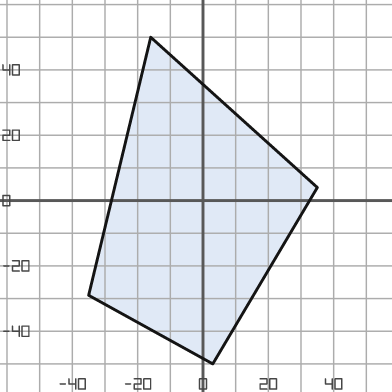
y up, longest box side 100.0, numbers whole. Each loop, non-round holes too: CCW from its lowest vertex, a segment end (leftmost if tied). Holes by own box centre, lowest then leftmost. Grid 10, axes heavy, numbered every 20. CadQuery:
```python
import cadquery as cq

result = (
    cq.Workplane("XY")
    .moveTo(3.0, -50.0)
    .lineTo(35.0, 4.0)
    .lineTo(-16.0, 50.0)
    .lineTo(-35.0, -29.0)
    .close()
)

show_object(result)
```